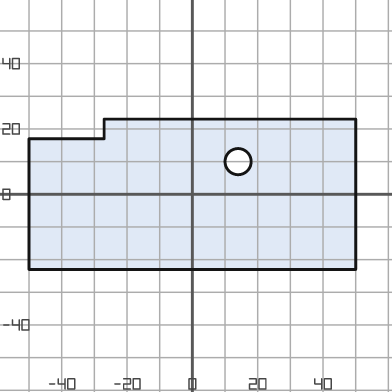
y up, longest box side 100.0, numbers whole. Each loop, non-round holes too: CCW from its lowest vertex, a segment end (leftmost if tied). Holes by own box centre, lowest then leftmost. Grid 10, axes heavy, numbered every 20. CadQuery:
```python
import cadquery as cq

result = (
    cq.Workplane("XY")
    .moveTo(-50.0, -23.0)
    .lineTo(50.0, -23.0)
    .lineTo(50.0, 23.0)
    .lineTo(-27.0, 23.0)
    .lineTo(-27.0, 17.0)
    .lineTo(-50.0, 17.0)
    .close()
    .moveTo(14.0, 10.0)
    .circle(4.0)
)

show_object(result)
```